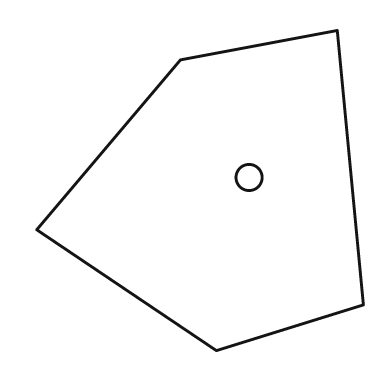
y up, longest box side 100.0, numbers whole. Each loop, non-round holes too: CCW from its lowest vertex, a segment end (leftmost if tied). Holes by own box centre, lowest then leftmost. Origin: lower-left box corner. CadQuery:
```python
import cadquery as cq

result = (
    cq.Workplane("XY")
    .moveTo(55.0, 0.0)
    .lineTo(100.0, 14.0)
    .lineTo(92.0, 98.0)
    .lineTo(44.0, 89.0)
    .lineTo(0.0, 37.0)
    .close()
    .moveTo(65.0, 53.0)
    .circle(4.0)
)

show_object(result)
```